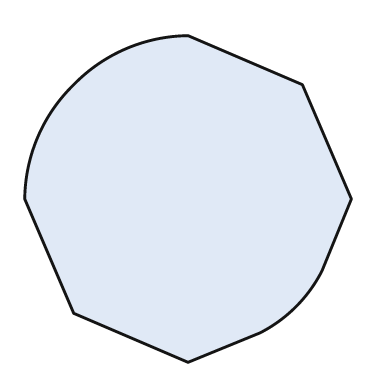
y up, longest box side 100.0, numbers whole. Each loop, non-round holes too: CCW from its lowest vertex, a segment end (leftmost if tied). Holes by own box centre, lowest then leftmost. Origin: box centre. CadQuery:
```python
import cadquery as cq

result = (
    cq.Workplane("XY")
    .moveTo(0.0, -50.0)
    .lineTo(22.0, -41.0)
    .threePointArc((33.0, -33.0), (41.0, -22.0))
    .lineTo(50.0, 0.0)
    .lineTo(35.0, 35.0)
    .lineTo(0.0, 50.0)
    .threePointArc((-19.0, 46.0), (-35.0, 35.0))
    .threePointArc((-46.0, 19.0), (-50.0, 0.0))
    .lineTo(-35.0, -35.0)
    .close()
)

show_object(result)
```